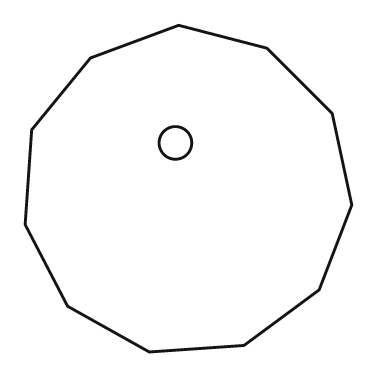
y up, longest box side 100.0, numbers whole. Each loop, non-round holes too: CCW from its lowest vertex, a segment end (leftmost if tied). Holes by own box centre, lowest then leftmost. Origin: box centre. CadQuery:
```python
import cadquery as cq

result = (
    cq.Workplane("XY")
    .moveTo(-12.0, -50.0)
    .lineTo(17.0, -48.0)
    .lineTo(40.0, -31.0)
    .lineTo(50.0, -5.0)
    .lineTo(44.0, 23.0)
    .lineTo(24.0, 43.0)
    .lineTo(-3.0, 50.0)
    .lineTo(-30.0, 40.0)
    .lineTo(-48.0, 18.0)
    .lineTo(-50.0, -11.0)
    .lineTo(-37.0, -36.0)
    .close()
    .moveTo(-4.0, 14.0)
    .circle(5.0)
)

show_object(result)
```